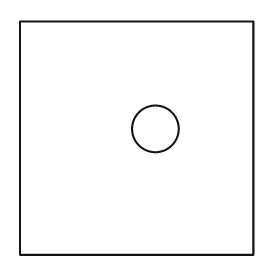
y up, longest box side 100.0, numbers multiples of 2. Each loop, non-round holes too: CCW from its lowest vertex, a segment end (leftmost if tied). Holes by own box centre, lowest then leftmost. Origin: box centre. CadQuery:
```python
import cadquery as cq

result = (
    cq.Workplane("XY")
    .moveTo(-50.0, -50.0)
    .lineTo(50.0, -50.0)
    .lineTo(50.0, 50.0)
    .lineTo(-50.0, 50.0)
    .close()
    .moveTo(8.0, 4.0)
    .circle(10.0)
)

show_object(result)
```